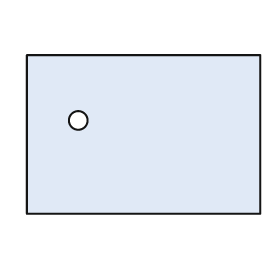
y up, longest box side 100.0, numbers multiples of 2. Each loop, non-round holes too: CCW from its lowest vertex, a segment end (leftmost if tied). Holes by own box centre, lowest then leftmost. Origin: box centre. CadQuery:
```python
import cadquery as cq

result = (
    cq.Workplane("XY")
    .moveTo(-50.0, -34.0)
    .lineTo(50.0, -34.0)
    .lineTo(50.0, 34.0)
    .lineTo(-50.0, 34.0)
    .close()
    .moveTo(-28.0, 6.0)
    .circle(4.0)
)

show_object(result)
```